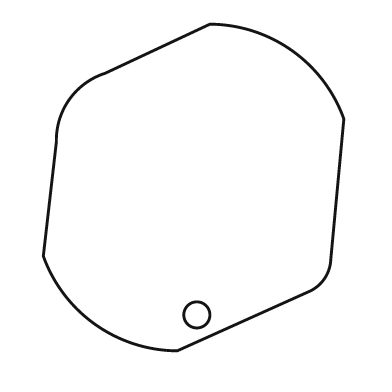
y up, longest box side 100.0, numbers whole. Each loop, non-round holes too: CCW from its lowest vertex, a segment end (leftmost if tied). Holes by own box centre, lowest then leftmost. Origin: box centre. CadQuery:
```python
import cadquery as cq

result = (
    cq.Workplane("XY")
    .moveTo(-5.0, -50.0)
    .lineTo(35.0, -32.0)
    .threePointArc((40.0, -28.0), (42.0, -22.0))
    .lineTo(46.0, 21.0)
    .threePointArc((30.0, 42.0), (5.0, 50.0))
    .lineTo(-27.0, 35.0)
    .threePointArc((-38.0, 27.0), (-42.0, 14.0))
    .lineTo(-46.0, -21.0)
    .threePointArc((-30.0, -42.0), (-5.0, -50.0))
    .close()
    .moveTo(1.0, -39.0)
    .circle(4.0)
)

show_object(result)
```